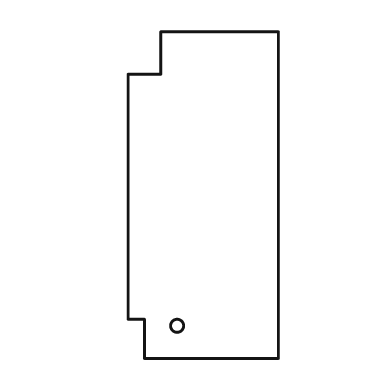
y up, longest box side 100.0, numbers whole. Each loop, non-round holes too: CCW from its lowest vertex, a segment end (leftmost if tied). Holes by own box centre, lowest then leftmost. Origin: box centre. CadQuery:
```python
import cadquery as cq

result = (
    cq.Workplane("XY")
    .moveTo(-18.0, -50.0)
    .lineTo(23.0, -50.0)
    .lineTo(23.0, 50.0)
    .lineTo(-13.0, 50.0)
    .lineTo(-13.0, 37.0)
    .lineTo(-23.0, 37.0)
    .lineTo(-23.0, -38.0)
    .lineTo(-18.0, -38.0)
    .close()
    .moveTo(-8.0, -40.0)
    .circle(2.0)
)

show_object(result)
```